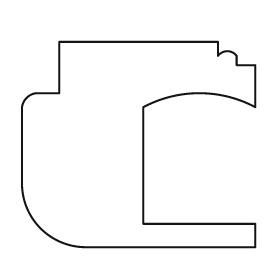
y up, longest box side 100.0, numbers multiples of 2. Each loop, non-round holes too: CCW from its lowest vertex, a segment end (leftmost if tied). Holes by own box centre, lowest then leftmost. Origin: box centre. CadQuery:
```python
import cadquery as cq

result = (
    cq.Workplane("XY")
    .moveTo(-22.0, -44.0)
    .lineTo(50.0, -44.0)
    .lineTo(50.0, -34.0)
    .lineTo(2.0, -34.0)
    .lineTo(2.0, 16.0)
    .threePointArc((26.0, 22.0), (50.0, 16.0))
    .lineTo(50.0, 34.0)
    .lineTo(42.0, 34.0)
    .lineTo(42.0, 38.0)
    .threePointArc((38.0, 40.0), (34.0, 38.0))
    .lineTo(34.0, 44.0)
    .lineTo(-34.0, 44.0)
    .lineTo(-34.0, 22.0)
    .lineTo(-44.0, 22.0)
    .threePointArc((-48.0, 20.0), (-50.0, 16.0))
    .lineTo(-50.0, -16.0)
    .threePointArc((-42.0, -36.0), (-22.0, -44.0))
    .close()
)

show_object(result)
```